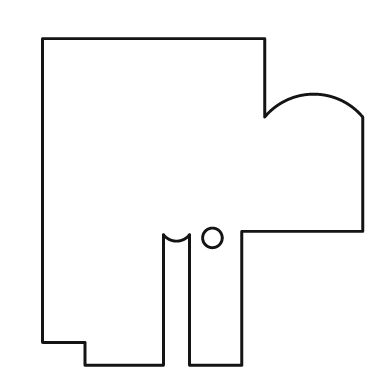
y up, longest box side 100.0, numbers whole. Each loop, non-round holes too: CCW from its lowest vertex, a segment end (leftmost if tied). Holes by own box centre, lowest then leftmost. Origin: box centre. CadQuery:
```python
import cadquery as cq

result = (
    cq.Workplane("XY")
    .moveTo(-36.0, -50.0)
    .lineTo(-12.0, -50.0)
    .lineTo(-12.0, -10.0)
    .threePointArc((-8.0, -12.0), (-4.0, -10.0))
    .lineTo(-4.0, -50.0)
    .lineTo(12.0, -50.0)
    .lineTo(12.0, -9.0)
    .lineTo(49.0, -9.0)
    .lineTo(49.0, 26.0)
    .threePointArc((34.0, 33.0), (19.0, 26.0))
    .lineTo(19.0, 50.0)
    .lineTo(-49.0, 50.0)
    .lineTo(-49.0, -43.0)
    .lineTo(-36.0, -43.0)
    .close()
    .moveTo(3.0, -11.0)
    .circle(3.0)
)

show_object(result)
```